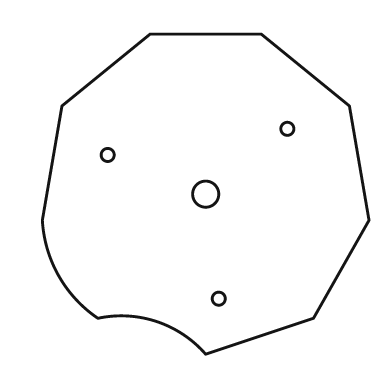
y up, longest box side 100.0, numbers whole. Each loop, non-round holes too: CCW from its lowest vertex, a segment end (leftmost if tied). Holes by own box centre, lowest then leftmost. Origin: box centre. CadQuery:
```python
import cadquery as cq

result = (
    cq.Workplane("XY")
    .moveTo(0.0, -49.0)
    .lineTo(33.0, -38.0)
    .lineTo(50.0, -8.0)
    .lineTo(44.0, 27.0)
    .lineTo(17.0, 49.0)
    .lineTo(-17.0, 49.0)
    .lineTo(-44.0, 27.0)
    .lineTo(-50.0, -8.0)
    .threePointArc((-45.0, -25.0), (-33.0, -38.0))
    .threePointArc((-15.0, -39.0), (0.0, -49.0))
    .close()
    .moveTo(4.0, -32.0)
    .circle(2.0)
    .moveTo(0.0, 0.0)
    .circle(4.0)
    .moveTo(-30.0, 12.0)
    .circle(2.0)
    .moveTo(25.0, 20.0)
    .circle(2.0)
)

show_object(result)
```